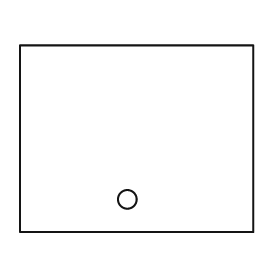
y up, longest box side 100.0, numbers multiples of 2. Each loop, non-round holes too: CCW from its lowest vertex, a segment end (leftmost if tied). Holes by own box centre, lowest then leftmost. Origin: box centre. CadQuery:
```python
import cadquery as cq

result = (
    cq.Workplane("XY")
    .moveTo(-50.0, -40.0)
    .lineTo(50.0, -40.0)
    .lineTo(50.0, 40.0)
    .lineTo(-50.0, 40.0)
    .close()
    .moveTo(-4.0, -26.0)
    .circle(4.0)
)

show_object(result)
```